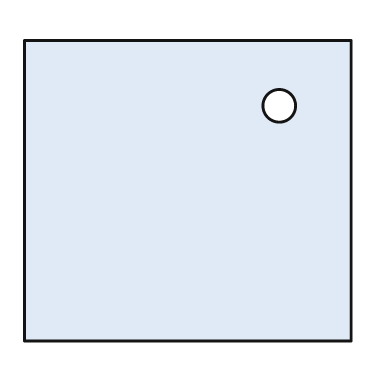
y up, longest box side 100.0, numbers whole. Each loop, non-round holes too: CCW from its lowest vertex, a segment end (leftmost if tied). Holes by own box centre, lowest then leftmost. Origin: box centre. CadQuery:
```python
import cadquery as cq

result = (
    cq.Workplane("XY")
    .moveTo(-50.0, -46.0)
    .lineTo(50.0, -46.0)
    .lineTo(50.0, 46.0)
    .lineTo(-50.0, 46.0)
    .close()
    .moveTo(28.0, 26.0)
    .circle(5.0)
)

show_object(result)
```